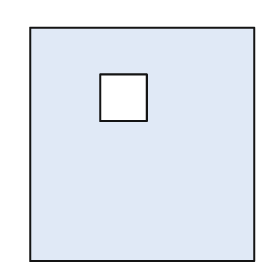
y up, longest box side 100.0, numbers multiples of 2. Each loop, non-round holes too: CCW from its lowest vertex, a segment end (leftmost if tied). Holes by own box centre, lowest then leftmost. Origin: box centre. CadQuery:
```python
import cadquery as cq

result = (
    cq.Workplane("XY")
    .moveTo(-48.0, -50.0)
    .lineTo(48.0, -50.0)
    .lineTo(48.0, 50.0)
    .lineTo(-48.0, 50.0)
    .close()
    .moveTo(-18.0, 10.0)
    .lineTo(2.0, 10.0)
    .lineTo(2.0, 30.0)
    .lineTo(-18.0, 30.0)
    .close()
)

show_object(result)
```